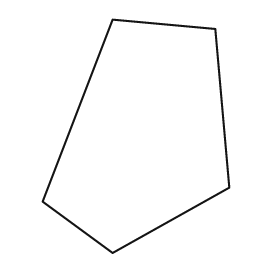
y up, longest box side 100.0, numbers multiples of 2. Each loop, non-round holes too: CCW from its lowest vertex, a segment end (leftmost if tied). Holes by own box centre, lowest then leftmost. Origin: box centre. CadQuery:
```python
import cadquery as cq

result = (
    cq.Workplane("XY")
    .moveTo(-10.0, -50.0)
    .lineTo(40.0, -22.0)
    .lineTo(34.0, 46.0)
    .lineTo(-10.0, 50.0)
    .lineTo(-40.0, -28.0)
    .close()
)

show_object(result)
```